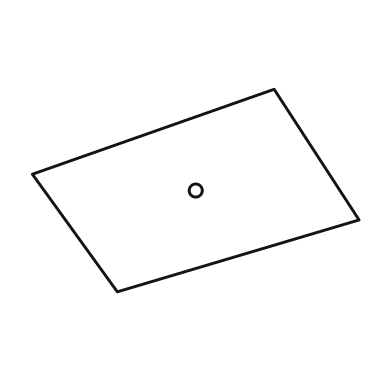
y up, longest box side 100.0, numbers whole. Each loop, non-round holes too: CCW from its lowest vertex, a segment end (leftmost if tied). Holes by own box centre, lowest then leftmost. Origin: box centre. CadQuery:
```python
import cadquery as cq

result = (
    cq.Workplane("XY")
    .moveTo(-24.0, -31.0)
    .lineTo(50.0, -9.0)
    .lineTo(24.0, 31.0)
    .lineTo(-50.0, 5.0)
    .close()
    .moveTo(0.0, 0.0)
    .circle(2.0)
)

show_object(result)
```